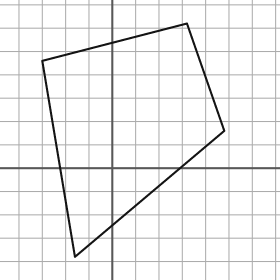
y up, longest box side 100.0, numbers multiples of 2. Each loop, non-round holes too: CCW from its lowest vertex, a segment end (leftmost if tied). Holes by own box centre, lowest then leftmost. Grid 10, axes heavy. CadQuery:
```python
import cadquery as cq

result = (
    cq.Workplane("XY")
    .moveTo(-16.0, -38.0)
    .lineTo(48.0, 16.0)
    .lineTo(32.0, 62.0)
    .lineTo(-30.0, 46.0)
    .close()
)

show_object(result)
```